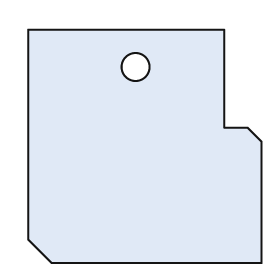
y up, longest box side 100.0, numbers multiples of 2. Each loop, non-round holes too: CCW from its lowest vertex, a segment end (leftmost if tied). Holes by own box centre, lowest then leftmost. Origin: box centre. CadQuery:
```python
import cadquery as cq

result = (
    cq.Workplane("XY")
    .moveTo(-40.0, -50.0)
    .lineTo(50.0, -50.0)
    .lineTo(50.0, 2.0)
    .lineTo(44.0, 8.0)
    .lineTo(34.0, 8.0)
    .lineTo(34.0, 50.0)
    .lineTo(-50.0, 50.0)
    .lineTo(-50.0, -40.0)
    .close()
    .moveTo(-4.0, 34.0)
    .circle(6.0)
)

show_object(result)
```